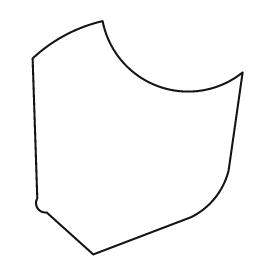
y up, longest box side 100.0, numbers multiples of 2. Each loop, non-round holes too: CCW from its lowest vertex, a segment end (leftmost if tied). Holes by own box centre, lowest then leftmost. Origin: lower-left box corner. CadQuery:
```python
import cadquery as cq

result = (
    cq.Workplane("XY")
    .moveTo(26.0, 0.0)
    .lineTo(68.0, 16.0)
    .threePointArc((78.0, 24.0), (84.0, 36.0))
    .lineTo(90.0, 78.0)
    .threePointArc((54.0, 72.0), (30.0, 100.0))
    .threePointArc((14.0, 94.0), (0.0, 84.0))
    .lineTo(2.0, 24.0)
    .threePointArc((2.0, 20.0), (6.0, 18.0))
    .close()
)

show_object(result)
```